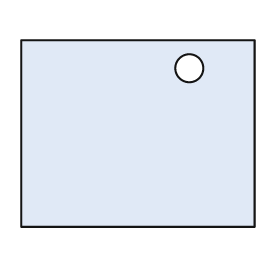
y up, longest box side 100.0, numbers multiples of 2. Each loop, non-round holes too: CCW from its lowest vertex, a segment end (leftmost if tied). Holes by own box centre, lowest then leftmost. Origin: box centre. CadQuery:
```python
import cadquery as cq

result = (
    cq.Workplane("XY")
    .moveTo(-50.0, -40.0)
    .lineTo(50.0, -40.0)
    .lineTo(50.0, 40.0)
    .lineTo(-50.0, 40.0)
    .close()
    .moveTo(22.0, 28.0)
    .circle(6.0)
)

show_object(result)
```